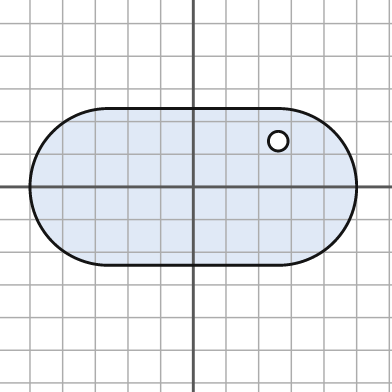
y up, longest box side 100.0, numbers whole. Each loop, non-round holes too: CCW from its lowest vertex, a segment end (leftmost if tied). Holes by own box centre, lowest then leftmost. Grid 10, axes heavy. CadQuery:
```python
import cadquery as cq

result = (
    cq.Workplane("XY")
    .moveTo(-26.0, -24.0)
    .lineTo(26.0, -24.0)
    .threePointArc((50.0, 0.0), (26.0, 24.0))
    .lineTo(-26.0, 24.0)
    .threePointArc((-50.0, 0.0), (-26.0, -24.0))
    .close()
    .moveTo(26.0, 14.0)
    .circle(3.0)
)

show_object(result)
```